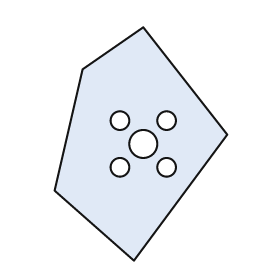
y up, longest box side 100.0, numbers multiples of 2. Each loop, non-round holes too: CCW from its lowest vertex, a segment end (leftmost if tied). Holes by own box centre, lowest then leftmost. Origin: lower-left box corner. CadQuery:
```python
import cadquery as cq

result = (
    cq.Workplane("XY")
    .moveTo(34.0, 0.0)
    .lineTo(74.0, 54.0)
    .lineTo(38.0, 100.0)
    .lineTo(12.0, 82.0)
    .lineTo(0.0, 30.0)
    .close()
    .moveTo(28.0, 40.0)
    .circle(4.0)
    .moveTo(48.0, 40.0)
    .circle(4.0)
    .moveTo(38.0, 50.0)
    .circle(6.0)
    .moveTo(28.0, 60.0)
    .circle(4.0)
    .moveTo(48.0, 60.0)
    .circle(4.0)
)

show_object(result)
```